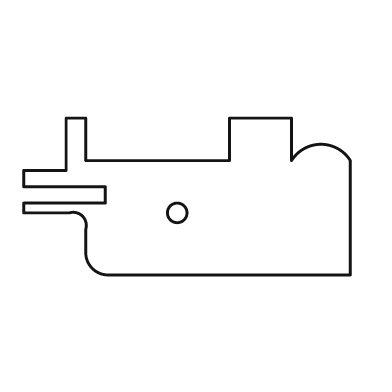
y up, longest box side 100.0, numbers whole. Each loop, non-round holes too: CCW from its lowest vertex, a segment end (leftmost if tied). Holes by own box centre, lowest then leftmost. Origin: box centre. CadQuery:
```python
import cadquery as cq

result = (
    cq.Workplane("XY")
    .moveTo(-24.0, -24.0)
    .lineTo(50.0, -24.0)
    .lineTo(50.0, 11.0)
    .threePointArc((41.0, 16.0), (32.0, 11.0))
    .lineTo(32.0, 24.0)
    .lineTo(13.0, 24.0)
    .lineTo(13.0, 11.0)
    .lineTo(-31.0, 11.0)
    .lineTo(-31.0, 24.0)
    .lineTo(-37.0, 24.0)
    .lineTo(-37.0, 8.0)
    .lineTo(-50.0, 8.0)
    .lineTo(-50.0, 3.0)
    .lineTo(-25.0, 3.0)
    .lineTo(-25.0, -2.0)
    .lineTo(-50.0, -2.0)
    .lineTo(-50.0, -5.0)
    .lineTo(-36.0, -5.0)
    .threePointArc((-32.0, -6.0), (-31.0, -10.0))
    .lineTo(-31.0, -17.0)
    .threePointArc((-29.0, -22.0), (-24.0, -24.0))
    .close()
    .moveTo(-3.0, -5.0)
    .circle(3.0)
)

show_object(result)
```